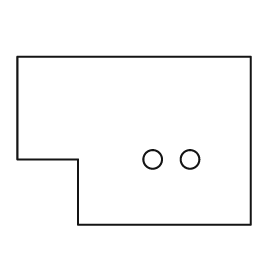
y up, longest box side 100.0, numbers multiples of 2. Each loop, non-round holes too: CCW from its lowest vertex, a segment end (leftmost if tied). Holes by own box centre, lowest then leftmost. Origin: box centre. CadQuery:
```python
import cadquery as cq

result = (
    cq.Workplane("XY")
    .moveTo(-24.0, -36.0)
    .lineTo(50.0, -36.0)
    .lineTo(50.0, 36.0)
    .lineTo(-50.0, 36.0)
    .lineTo(-50.0, -8.0)
    .lineTo(-24.0, -8.0)
    .close()
    .moveTo(8.0, -8.0)
    .circle(4.0)
    .moveTo(24.0, -8.0)
    .circle(4.0)
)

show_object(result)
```